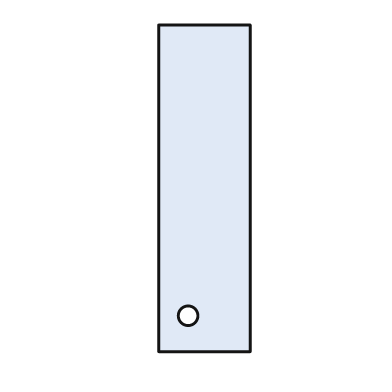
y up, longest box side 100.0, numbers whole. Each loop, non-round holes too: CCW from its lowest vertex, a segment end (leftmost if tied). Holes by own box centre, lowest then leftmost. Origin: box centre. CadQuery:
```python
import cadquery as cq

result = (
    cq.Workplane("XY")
    .moveTo(-14.0, -50.0)
    .lineTo(14.0, -50.0)
    .lineTo(14.0, 50.0)
    .lineTo(-14.0, 50.0)
    .close()
    .moveTo(-5.0, -39.0)
    .circle(3.0)
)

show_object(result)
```